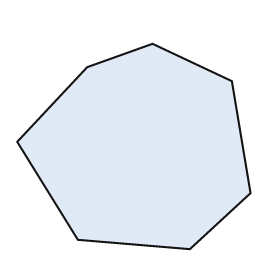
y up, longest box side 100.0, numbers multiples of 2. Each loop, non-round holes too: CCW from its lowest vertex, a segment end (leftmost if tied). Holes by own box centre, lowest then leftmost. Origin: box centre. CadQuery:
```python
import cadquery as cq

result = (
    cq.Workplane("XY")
    .moveTo(24.0, -44.0)
    .lineTo(50.0, -20.0)
    .lineTo(42.0, 28.0)
    .lineTo(8.0, 44.0)
    .lineTo(-20.0, 34.0)
    .lineTo(-50.0, 2.0)
    .lineTo(-24.0, -40.0)
    .close()
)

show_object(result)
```